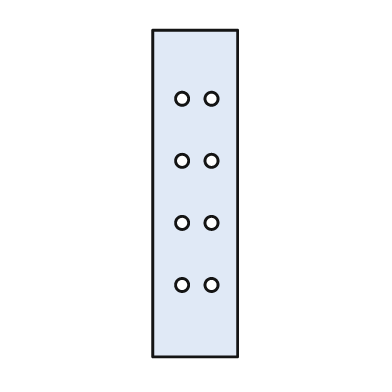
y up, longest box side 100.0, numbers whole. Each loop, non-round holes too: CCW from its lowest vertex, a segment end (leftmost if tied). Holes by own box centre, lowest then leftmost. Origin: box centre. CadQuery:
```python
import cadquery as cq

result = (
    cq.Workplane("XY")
    .moveTo(-13.0, -50.0)
    .lineTo(13.0, -50.0)
    .lineTo(13.0, 50.0)
    .lineTo(-13.0, 50.0)
    .close()
    .moveTo(-4.0, -28.0)
    .circle(2.0)
    .moveTo(5.0, -28.0)
    .circle(2.0)
    .moveTo(-4.0, -9.0)
    .circle(2.0)
    .moveTo(5.0, -9.0)
    .circle(2.0)
    .moveTo(-4.0, 10.0)
    .circle(2.0)
    .moveTo(5.0, 10.0)
    .circle(2.0)
    .moveTo(-4.0, 29.0)
    .circle(2.0)
    .moveTo(5.0, 29.0)
    .circle(2.0)
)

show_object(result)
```